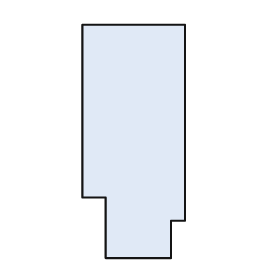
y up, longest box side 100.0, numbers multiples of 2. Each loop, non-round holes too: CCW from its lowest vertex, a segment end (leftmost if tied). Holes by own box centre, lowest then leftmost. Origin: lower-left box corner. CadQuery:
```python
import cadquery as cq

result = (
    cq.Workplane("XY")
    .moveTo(10.0, 0.0)
    .lineTo(38.0, 0.0)
    .lineTo(38.0, 16.0)
    .lineTo(44.0, 16.0)
    .lineTo(44.0, 100.0)
    .lineTo(0.0, 100.0)
    .lineTo(0.0, 26.0)
    .lineTo(10.0, 26.0)
    .close()
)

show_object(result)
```